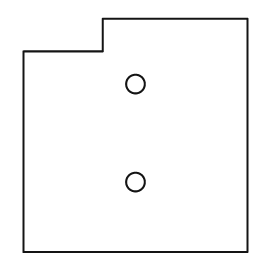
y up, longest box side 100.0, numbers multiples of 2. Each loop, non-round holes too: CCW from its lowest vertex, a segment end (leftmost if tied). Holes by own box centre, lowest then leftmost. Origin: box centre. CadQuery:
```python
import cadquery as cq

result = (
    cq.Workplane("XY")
    .moveTo(-48.0, -50.0)
    .lineTo(48.0, -50.0)
    .lineTo(48.0, 50.0)
    .lineTo(-14.0, 50.0)
    .lineTo(-14.0, 36.0)
    .lineTo(-48.0, 36.0)
    .close()
    .moveTo(0.0, -20.0)
    .circle(4.0)
    .moveTo(0.0, 22.0)
    .circle(4.0)
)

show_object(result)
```